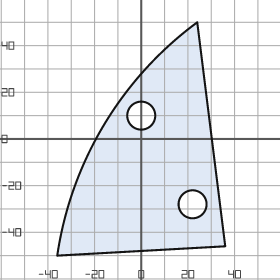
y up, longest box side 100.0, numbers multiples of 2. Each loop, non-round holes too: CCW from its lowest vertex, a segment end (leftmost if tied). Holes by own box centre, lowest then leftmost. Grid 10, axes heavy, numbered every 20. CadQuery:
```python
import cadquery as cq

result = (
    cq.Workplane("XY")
    .moveTo(-36.0, -50.0)
    .lineTo(36.0, -46.0)
    .lineTo(24.0, 50.0)
    .threePointArc((-16.0, 6.0), (-36.0, -50.0))
    .close()
    .moveTo(22.0, -28.0)
    .circle(6.0)
    .moveTo(0.0, 10.0)
    .circle(6.0)
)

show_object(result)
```